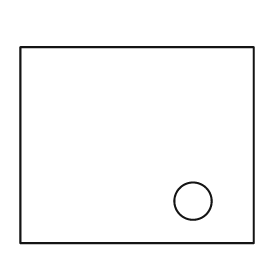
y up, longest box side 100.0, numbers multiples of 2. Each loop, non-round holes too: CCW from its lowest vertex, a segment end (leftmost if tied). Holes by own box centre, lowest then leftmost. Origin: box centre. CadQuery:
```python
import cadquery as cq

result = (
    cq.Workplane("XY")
    .moveTo(-50.0, -42.0)
    .lineTo(50.0, -42.0)
    .lineTo(50.0, 42.0)
    .lineTo(-50.0, 42.0)
    .close()
    .moveTo(24.0, -24.0)
    .circle(8.0)
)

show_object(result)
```